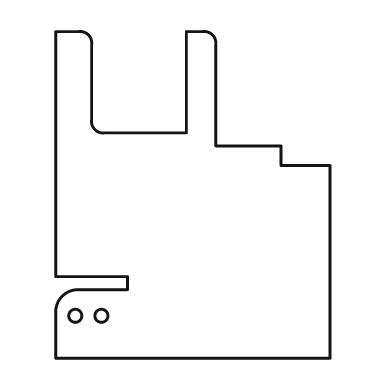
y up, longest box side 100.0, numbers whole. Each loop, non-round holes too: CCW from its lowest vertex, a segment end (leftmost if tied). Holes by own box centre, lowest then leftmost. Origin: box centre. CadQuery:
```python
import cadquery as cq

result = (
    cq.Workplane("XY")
    .moveTo(-42.0, -50.0)
    .lineTo(42.0, -50.0)
    .lineTo(42.0, 9.0)
    .lineTo(27.0, 9.0)
    .lineTo(27.0, 15.0)
    .lineTo(7.0, 15.0)
    .lineTo(7.0, 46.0)
    .threePointArc((6.0, 49.0), (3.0, 50.0))
    .lineTo(-2.0, 50.0)
    .lineTo(-2.0, 19.0)
    .lineTo(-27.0, 19.0)
    .threePointArc((-30.0, 20.0), (-31.0, 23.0))
    .lineTo(-31.0, 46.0)
    .threePointArc((-32.0, 49.0), (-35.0, 50.0))
    .lineTo(-42.0, 50.0)
    .lineTo(-42.0, -25.0)
    .lineTo(-20.0, -25.0)
    .lineTo(-20.0, -29.0)
    .lineTo(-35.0, -29.0)
    .threePointArc((-40.0, -31.0), (-42.0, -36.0))
    .close()
    .moveTo(-36.0, -37.0)
    .circle(2.0)
    .moveTo(-28.0, -37.0)
    .circle(2.0)
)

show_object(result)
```